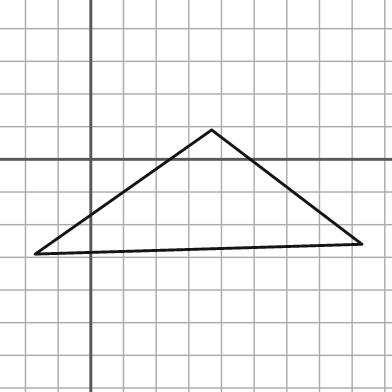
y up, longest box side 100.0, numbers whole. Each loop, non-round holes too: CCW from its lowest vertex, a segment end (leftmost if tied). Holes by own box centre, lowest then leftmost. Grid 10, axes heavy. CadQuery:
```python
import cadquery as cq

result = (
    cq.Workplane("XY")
    .moveTo(-17.0, -29.0)
    .lineTo(83.0, -26.0)
    .lineTo(37.0, 9.0)
    .close()
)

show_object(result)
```